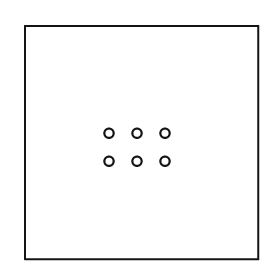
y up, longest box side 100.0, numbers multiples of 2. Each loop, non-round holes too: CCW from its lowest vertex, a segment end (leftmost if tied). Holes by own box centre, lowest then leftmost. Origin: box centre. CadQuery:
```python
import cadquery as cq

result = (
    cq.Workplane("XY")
    .moveTo(-50.0, -50.0)
    .lineTo(50.0, -50.0)
    .lineTo(50.0, 50.0)
    .lineTo(-50.0, 50.0)
    .close()
    .moveTo(-14.0, -8.0)
    .circle(2.0)
    .moveTo(-2.0, -8.0)
    .circle(2.0)
    .moveTo(10.0, -8.0)
    .circle(2.0)
    .moveTo(-14.0, 4.0)
    .circle(2.0)
    .moveTo(-2.0, 4.0)
    .circle(2.0)
    .moveTo(10.0, 4.0)
    .circle(2.0)
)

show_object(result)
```